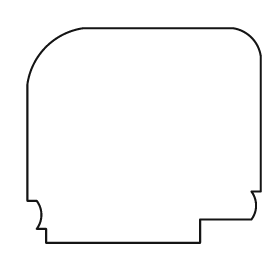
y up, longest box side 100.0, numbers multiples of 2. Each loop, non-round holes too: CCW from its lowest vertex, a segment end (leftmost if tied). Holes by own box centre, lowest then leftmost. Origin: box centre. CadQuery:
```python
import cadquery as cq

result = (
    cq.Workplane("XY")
    .moveTo(-42.0, -46.0)
    .lineTo(24.0, -46.0)
    .lineTo(24.0, -36.0)
    .lineTo(46.0, -36.0)
    .threePointArc((48.0, -30.0), (46.0, -24.0))
    .lineTo(50.0, -24.0)
    .lineTo(50.0, 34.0)
    .threePointArc((46.0, 42.0), (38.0, 46.0))
    .lineTo(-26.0, 46.0)
    .threePointArc((-42.0, 38.0), (-50.0, 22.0))
    .lineTo(-50.0, -28.0)
    .lineTo(-46.0, -28.0)
    .threePointArc((-44.0, -34.0), (-46.0, -40.0))
    .lineTo(-42.0, -40.0)
    .close()
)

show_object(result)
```